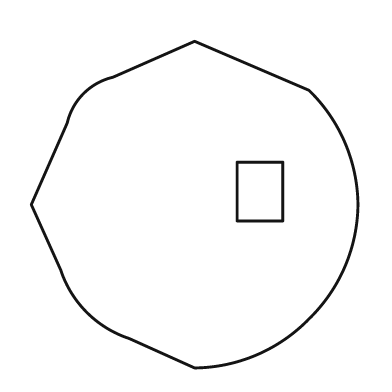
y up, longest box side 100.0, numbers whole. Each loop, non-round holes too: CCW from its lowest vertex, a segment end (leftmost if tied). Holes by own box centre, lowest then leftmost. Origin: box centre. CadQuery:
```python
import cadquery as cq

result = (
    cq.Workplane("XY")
    .moveTo(0.0, -50.0)
    .threePointArc((19.0, -46.0), (35.0, -35.0))
    .threePointArc((46.0, -19.0), (50.0, 0.0))
    .threePointArc((46.0, 19.0), (35.0, 35.0))
    .lineTo(0.0, 50.0)
    .lineTo(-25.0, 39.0)
    .threePointArc((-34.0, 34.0), (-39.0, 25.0))
    .lineTo(-50.0, 0.0)
    .lineTo(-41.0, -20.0)
    .threePointArc((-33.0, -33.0), (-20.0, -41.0))
    .close()
    .moveTo(13.0, -5.0)
    .lineTo(27.0, -5.0)
    .lineTo(27.0, 13.0)
    .lineTo(13.0, 13.0)
    .close()
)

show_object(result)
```